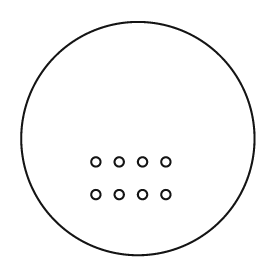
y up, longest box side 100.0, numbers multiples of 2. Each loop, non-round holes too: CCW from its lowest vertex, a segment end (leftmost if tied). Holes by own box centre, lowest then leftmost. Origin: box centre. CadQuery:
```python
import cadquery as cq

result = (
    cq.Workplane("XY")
    .moveTo(0.0, 0.0)
    .circle(50.0)
    .moveTo(-18.0, -24.0)
    .circle(2.0)
    .moveTo(-8.0, -24.0)
    .circle(2.0)
    .moveTo(2.0, -24.0)
    .circle(2.0)
    .moveTo(12.0, -24.0)
    .circle(2.0)
    .moveTo(-18.0, -10.0)
    .circle(2.0)
    .moveTo(-8.0, -10.0)
    .circle(2.0)
    .moveTo(2.0, -10.0)
    .circle(2.0)
    .moveTo(12.0, -10.0)
    .circle(2.0)
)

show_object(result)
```